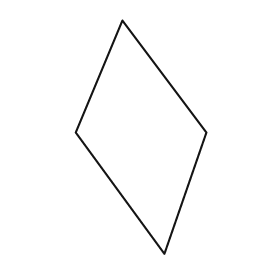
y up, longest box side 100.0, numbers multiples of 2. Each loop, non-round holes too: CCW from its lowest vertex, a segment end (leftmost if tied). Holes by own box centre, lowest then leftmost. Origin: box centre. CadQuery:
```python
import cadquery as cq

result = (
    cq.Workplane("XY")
    .moveTo(10.0, -50.0)
    .lineTo(28.0, 2.0)
    .lineTo(-8.0, 50.0)
    .lineTo(-28.0, 2.0)
    .close()
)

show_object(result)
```